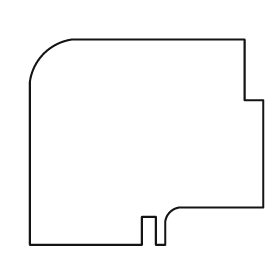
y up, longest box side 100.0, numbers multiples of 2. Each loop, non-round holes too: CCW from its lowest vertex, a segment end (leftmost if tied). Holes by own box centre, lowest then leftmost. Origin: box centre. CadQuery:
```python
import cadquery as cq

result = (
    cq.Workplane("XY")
    .moveTo(-50.0, -44.0)
    .lineTo(-2.0, -44.0)
    .lineTo(-2.0, -32.0)
    .lineTo(4.0, -32.0)
    .lineTo(4.0, -44.0)
    .lineTo(8.0, -44.0)
    .lineTo(8.0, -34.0)
    .threePointArc((10.0, -30.0), (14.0, -28.0))
    .lineTo(50.0, -28.0)
    .lineTo(50.0, 18.0)
    .lineTo(42.0, 18.0)
    .lineTo(42.0, 44.0)
    .lineTo(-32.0, 44.0)
    .threePointArc((-44.0, 38.0), (-50.0, 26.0))
    .close()
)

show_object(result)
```